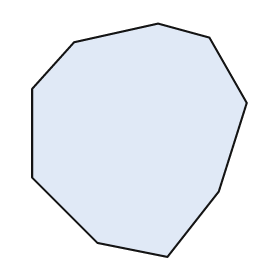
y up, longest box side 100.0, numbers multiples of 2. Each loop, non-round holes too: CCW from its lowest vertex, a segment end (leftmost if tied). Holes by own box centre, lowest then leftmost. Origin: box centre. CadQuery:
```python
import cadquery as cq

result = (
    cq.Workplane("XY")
    .moveTo(12.0, -50.0)
    .lineTo(34.0, -22.0)
    .lineTo(46.0, 16.0)
    .lineTo(30.0, 44.0)
    .lineTo(8.0, 50.0)
    .lineTo(-28.0, 42.0)
    .lineTo(-46.0, 22.0)
    .lineTo(-46.0, -16.0)
    .lineTo(-18.0, -44.0)
    .close()
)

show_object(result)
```